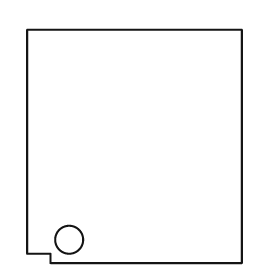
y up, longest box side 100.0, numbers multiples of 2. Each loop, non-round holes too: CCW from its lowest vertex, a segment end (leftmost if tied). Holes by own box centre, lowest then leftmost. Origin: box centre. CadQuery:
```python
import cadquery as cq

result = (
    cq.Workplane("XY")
    .moveTo(-36.0, -50.0)
    .lineTo(46.0, -50.0)
    .lineTo(46.0, 50.0)
    .lineTo(-46.0, 50.0)
    .lineTo(-46.0, -46.0)
    .lineTo(-36.0, -46.0)
    .close()
    .moveTo(-28.0, -40.0)
    .circle(6.0)
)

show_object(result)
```